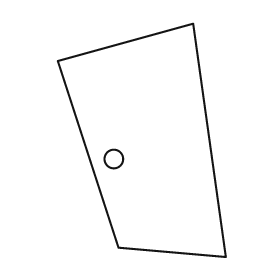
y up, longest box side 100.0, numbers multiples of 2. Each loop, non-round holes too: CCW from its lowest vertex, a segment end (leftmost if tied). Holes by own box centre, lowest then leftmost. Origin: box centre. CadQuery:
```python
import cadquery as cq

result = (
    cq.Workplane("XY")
    .moveTo(36.0, -50.0)
    .lineTo(22.0, 50.0)
    .lineTo(-36.0, 34.0)
    .lineTo(-10.0, -46.0)
    .close()
    .moveTo(-12.0, -8.0)
    .circle(4.0)
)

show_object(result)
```